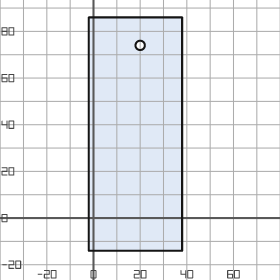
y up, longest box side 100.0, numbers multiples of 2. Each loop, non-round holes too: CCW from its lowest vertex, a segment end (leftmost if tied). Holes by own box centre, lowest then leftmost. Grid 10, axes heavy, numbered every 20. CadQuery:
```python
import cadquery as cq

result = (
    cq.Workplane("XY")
    .moveTo(-2.0, -14.0)
    .lineTo(38.0, -14.0)
    .lineTo(38.0, 86.0)
    .lineTo(-2.0, 86.0)
    .close()
    .moveTo(20.0, 74.0)
    .circle(2.0)
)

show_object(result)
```